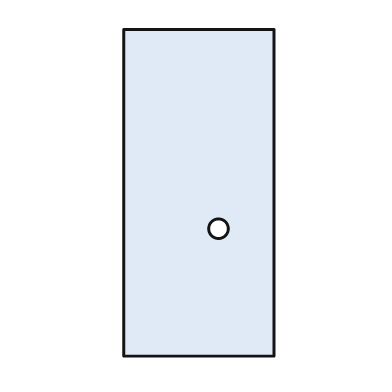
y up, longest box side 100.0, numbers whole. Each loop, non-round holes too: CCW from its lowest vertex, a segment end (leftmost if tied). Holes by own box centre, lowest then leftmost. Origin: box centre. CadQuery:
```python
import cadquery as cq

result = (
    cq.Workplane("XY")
    .moveTo(-23.0, -50.0)
    .lineTo(23.0, -50.0)
    .lineTo(23.0, 50.0)
    .lineTo(-23.0, 50.0)
    .close()
    .moveTo(6.0, -11.0)
    .circle(3.0)
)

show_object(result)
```